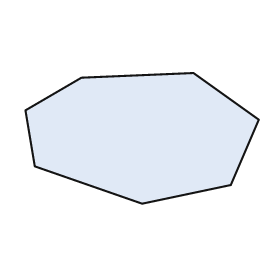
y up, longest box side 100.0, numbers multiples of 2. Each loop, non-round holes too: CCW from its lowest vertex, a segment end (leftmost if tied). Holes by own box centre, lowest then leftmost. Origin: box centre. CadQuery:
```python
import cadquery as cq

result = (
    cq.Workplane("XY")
    .moveTo(0.0, -28.0)
    .lineTo(38.0, -20.0)
    .lineTo(50.0, 8.0)
    .lineTo(22.0, 28.0)
    .lineTo(-26.0, 26.0)
    .lineTo(-50.0, 12.0)
    .lineTo(-46.0, -12.0)
    .close()
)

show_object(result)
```